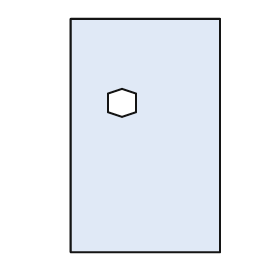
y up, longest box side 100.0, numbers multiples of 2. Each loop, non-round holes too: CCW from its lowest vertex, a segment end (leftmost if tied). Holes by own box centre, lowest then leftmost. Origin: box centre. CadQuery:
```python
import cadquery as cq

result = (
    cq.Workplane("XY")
    .moveTo(-32.0, -50.0)
    .lineTo(32.0, -50.0)
    .lineTo(32.0, 50.0)
    .lineTo(-32.0, 50.0)
    .close()
    .moveTo(-10.0, 8.0)
    .lineTo(-4.0, 10.0)
    .lineTo(-4.0, 18.0)
    .lineTo(-10.0, 20.0)
    .lineTo(-16.0, 18.0)
    .lineTo(-16.0, 10.0)
    .close()
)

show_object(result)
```